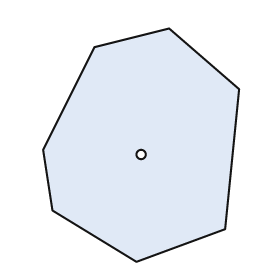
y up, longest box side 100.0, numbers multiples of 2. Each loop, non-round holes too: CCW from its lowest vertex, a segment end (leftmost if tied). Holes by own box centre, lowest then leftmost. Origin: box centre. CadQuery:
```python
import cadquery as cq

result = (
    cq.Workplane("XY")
    .moveTo(-2.0, -50.0)
    .lineTo(36.0, -36.0)
    .lineTo(42.0, 24.0)
    .lineTo(12.0, 50.0)
    .lineTo(-20.0, 42.0)
    .lineTo(-42.0, -2.0)
    .lineTo(-38.0, -28.0)
    .close()
    .moveTo(0.0, -4.0)
    .circle(2.0)
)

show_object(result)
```